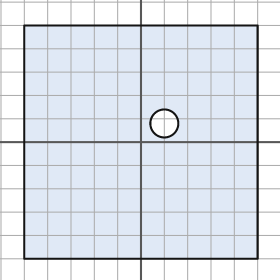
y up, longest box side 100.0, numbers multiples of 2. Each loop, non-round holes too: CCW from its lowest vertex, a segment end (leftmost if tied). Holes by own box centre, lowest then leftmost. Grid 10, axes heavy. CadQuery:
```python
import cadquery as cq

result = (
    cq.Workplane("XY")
    .moveTo(-50.0, -50.0)
    .lineTo(50.0, -50.0)
    .lineTo(50.0, 50.0)
    .lineTo(-50.0, 50.0)
    .close()
    .moveTo(10.0, 8.0)
    .circle(6.0)
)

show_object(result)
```